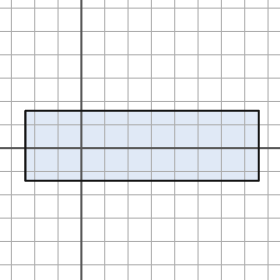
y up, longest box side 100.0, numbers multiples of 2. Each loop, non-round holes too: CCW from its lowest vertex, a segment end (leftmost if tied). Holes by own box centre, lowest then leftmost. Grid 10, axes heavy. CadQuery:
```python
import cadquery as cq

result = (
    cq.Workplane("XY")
    .moveTo(-24.0, -14.0)
    .lineTo(76.0, -14.0)
    .lineTo(76.0, 16.0)
    .lineTo(-24.0, 16.0)
    .close()
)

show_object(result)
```